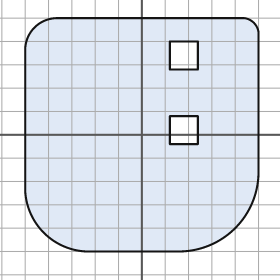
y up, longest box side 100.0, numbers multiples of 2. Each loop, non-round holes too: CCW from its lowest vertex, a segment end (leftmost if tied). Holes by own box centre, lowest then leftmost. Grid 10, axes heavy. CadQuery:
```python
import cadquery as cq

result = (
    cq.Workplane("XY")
    .moveTo(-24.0, -50.0)
    .lineTo(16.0, -50.0)
    .threePointArc((40.0, -40.0), (50.0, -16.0))
    .lineTo(50.0, 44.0)
    .threePointArc((48.0, 48.0), (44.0, 50.0))
    .lineTo(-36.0, 50.0)
    .threePointArc((-46.0, 46.0), (-50.0, 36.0))
    .lineTo(-50.0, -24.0)
    .threePointArc((-42.0, -42.0), (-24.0, -50.0))
    .close()
    .moveTo(12.0, -4.0)
    .lineTo(24.0, -4.0)
    .lineTo(24.0, 8.0)
    .lineTo(12.0, 8.0)
    .close()
    .moveTo(12.0, 28.0)
    .lineTo(24.0, 28.0)
    .lineTo(24.0, 40.0)
    .lineTo(12.0, 40.0)
    .close()
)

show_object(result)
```